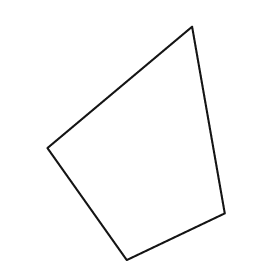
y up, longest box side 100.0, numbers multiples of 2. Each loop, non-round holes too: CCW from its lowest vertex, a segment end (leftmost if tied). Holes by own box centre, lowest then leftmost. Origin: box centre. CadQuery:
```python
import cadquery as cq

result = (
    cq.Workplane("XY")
    .moveTo(-4.0, -50.0)
    .lineTo(38.0, -30.0)
    .lineTo(24.0, 50.0)
    .lineTo(-38.0, -2.0)
    .close()
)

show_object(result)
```